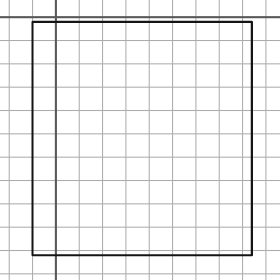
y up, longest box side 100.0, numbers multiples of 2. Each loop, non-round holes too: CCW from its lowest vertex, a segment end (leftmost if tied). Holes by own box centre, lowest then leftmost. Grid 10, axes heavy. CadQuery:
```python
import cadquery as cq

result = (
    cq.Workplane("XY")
    .moveTo(-10.0, -102.0)
    .lineTo(84.0, -102.0)
    .lineTo(84.0, -2.0)
    .lineTo(-10.0, -2.0)
    .close()
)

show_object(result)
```